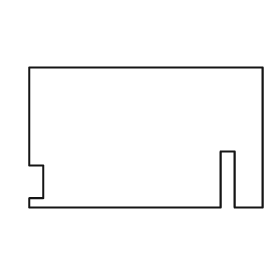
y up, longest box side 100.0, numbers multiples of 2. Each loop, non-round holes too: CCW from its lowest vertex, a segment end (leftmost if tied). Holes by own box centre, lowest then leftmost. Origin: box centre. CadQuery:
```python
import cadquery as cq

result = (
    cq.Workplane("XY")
    .moveTo(-50.0, -30.0)
    .lineTo(32.0, -30.0)
    .lineTo(32.0, -6.0)
    .lineTo(38.0, -6.0)
    .lineTo(38.0, -30.0)
    .lineTo(50.0, -30.0)
    .lineTo(50.0, 30.0)
    .lineTo(-50.0, 30.0)
    .lineTo(-50.0, -12.0)
    .lineTo(-44.0, -12.0)
    .lineTo(-44.0, -26.0)
    .lineTo(-50.0, -26.0)
    .close()
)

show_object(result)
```